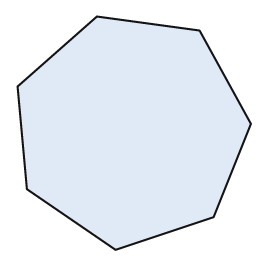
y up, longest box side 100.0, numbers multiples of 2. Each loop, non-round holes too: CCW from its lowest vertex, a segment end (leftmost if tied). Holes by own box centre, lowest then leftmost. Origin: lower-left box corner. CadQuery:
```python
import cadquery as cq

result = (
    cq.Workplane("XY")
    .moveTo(42.0, 0.0)
    .lineTo(84.0, 14.0)
    .lineTo(100.0, 54.0)
    .lineTo(78.0, 94.0)
    .lineTo(34.0, 100.0)
    .lineTo(0.0, 70.0)
    .lineTo(4.0, 26.0)
    .close()
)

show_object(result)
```